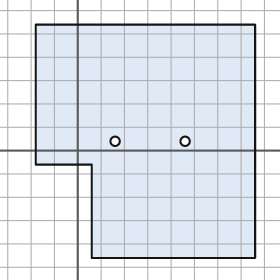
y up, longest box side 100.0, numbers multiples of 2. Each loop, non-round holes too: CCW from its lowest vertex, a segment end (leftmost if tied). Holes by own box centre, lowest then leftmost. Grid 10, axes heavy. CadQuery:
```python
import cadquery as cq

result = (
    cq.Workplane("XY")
    .moveTo(6.0, -46.0)
    .lineTo(76.0, -46.0)
    .lineTo(76.0, 54.0)
    .lineTo(-18.0, 54.0)
    .lineTo(-18.0, -6.0)
    .lineTo(6.0, -6.0)
    .close()
    .moveTo(16.0, 4.0)
    .circle(2.0)
    .moveTo(46.0, 4.0)
    .circle(2.0)
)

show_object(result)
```